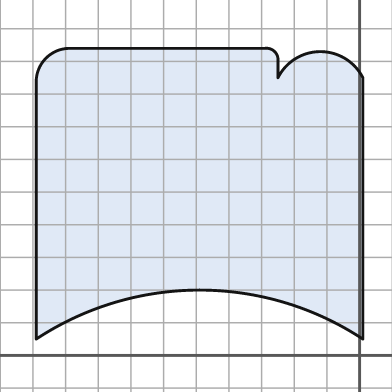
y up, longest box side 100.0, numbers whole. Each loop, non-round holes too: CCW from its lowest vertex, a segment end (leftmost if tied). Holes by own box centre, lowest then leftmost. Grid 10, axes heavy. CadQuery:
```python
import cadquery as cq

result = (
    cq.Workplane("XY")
    .moveTo(-99.0, 5.0)
    .threePointArc((-49.0, 20.0), (1.0, 5.0))
    .lineTo(1.0, 85.0)
    .threePointArc((-12.0, 93.0), (-25.0, 85.0))
    .lineTo(-25.0, 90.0)
    .threePointArc((-26.0, 93.0), (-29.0, 94.0))
    .lineTo(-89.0, 94.0)
    .threePointArc((-96.0, 91.0), (-99.0, 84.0))
    .close()
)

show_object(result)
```